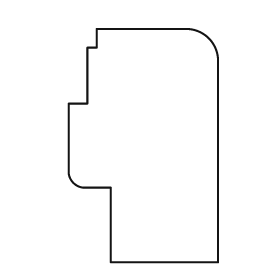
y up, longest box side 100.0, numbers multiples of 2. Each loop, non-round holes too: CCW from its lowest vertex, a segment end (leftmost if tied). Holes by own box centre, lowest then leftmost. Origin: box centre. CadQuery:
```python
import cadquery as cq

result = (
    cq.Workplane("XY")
    .moveTo(-14.0, -50.0)
    .lineTo(32.0, -50.0)
    .lineTo(32.0, 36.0)
    .threePointArc((28.0, 46.0), (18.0, 50.0))
    .lineTo(-20.0, 50.0)
    .lineTo(-20.0, 42.0)
    .lineTo(-24.0, 42.0)
    .lineTo(-24.0, 18.0)
    .lineTo(-32.0, 18.0)
    .lineTo(-32.0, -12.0)
    .threePointArc((-30.0, -16.0), (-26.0, -18.0))
    .lineTo(-14.0, -18.0)
    .close()
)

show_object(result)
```